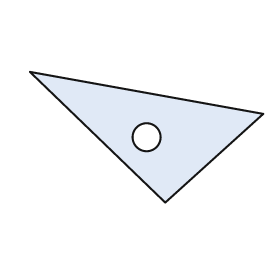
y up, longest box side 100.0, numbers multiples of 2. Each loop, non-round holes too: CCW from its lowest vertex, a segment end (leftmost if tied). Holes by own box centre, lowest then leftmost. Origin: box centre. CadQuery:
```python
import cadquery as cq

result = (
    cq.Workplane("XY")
    .moveTo(8.0, -28.0)
    .lineTo(50.0, 10.0)
    .lineTo(-50.0, 28.0)
    .close()
    .moveTo(0.0, 0.0)
    .circle(6.0)
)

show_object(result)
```